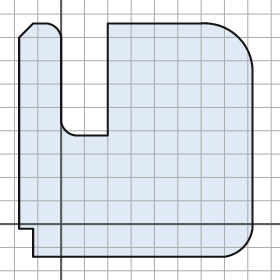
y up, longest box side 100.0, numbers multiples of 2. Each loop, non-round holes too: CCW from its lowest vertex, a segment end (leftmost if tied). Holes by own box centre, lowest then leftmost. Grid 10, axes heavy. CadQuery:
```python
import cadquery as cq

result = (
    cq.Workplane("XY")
    .moveTo(-12.0, -14.0)
    .lineTo(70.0, -14.0)
    .threePointArc((78.0, -10.0), (82.0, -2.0))
    .lineTo(82.0, 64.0)
    .threePointArc((76.0, 80.0), (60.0, 86.0))
    .lineTo(20.0, 86.0)
    .lineTo(20.0, 38.0)
    .lineTo(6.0, 38.0)
    .threePointArc((2.0, 40.0), (0.0, 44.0))
    .lineTo(0.0, 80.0)
    .threePointArc((-2.0, 84.0), (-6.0, 86.0))
    .lineTo(-12.0, 86.0)
    .lineTo(-18.0, 80.0)
    .lineTo(-18.0, -2.0)
    .lineTo(-12.0, -2.0)
    .close()
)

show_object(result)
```